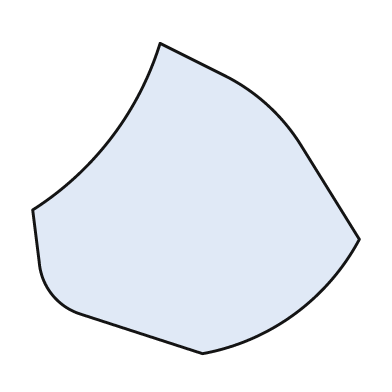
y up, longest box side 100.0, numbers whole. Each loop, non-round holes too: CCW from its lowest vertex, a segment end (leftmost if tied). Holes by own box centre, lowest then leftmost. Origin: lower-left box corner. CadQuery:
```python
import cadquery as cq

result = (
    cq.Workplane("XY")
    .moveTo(52.0, 0.0)
    .threePointArc((80.0, 12.0), (100.0, 35.0))
    .lineTo(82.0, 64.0)
    .threePointArc((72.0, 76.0), (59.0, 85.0))
    .lineTo(39.0, 95.0)
    .threePointArc((24.0, 66.0), (0.0, 44.0))
    .lineTo(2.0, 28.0)
    .threePointArc((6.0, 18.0), (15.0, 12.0))
    .close()
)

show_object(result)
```